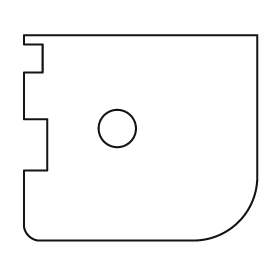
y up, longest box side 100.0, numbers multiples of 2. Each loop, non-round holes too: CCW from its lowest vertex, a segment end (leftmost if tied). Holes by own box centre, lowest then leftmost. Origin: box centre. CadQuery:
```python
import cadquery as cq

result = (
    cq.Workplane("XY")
    .moveTo(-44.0, -44.0)
    .lineTo(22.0, -44.0)
    .threePointArc((42.0, -36.0), (50.0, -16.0))
    .lineTo(50.0, 44.0)
    .lineTo(-50.0, 44.0)
    .lineTo(-50.0, 40.0)
    .lineTo(-42.0, 40.0)
    .lineTo(-42.0, 28.0)
    .lineTo(-50.0, 28.0)
    .lineTo(-50.0, 8.0)
    .lineTo(-40.0, 8.0)
    .lineTo(-40.0, -14.0)
    .lineTo(-50.0, -14.0)
    .lineTo(-50.0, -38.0)
    .threePointArc((-48.0, -42.0), (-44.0, -44.0))
    .close()
    .moveTo(-10.0, 4.0)
    .circle(8.0)
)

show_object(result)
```